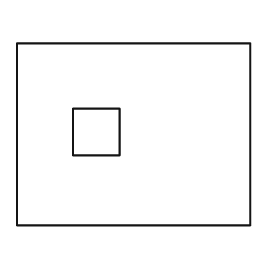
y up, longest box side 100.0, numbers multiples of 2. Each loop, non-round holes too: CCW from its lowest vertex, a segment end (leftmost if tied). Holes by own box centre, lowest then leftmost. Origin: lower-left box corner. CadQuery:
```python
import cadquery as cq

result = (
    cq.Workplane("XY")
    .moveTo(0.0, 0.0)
    .lineTo(100.0, 0.0)
    .lineTo(100.0, 78.0)
    .lineTo(0.0, 78.0)
    .close()
    .moveTo(24.0, 30.0)
    .lineTo(44.0, 30.0)
    .lineTo(44.0, 50.0)
    .lineTo(24.0, 50.0)
    .close()
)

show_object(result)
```